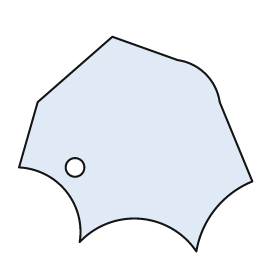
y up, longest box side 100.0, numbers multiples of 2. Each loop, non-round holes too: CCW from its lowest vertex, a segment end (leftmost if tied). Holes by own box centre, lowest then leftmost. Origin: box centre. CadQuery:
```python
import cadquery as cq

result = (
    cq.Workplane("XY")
    .moveTo(26.0, -46.0)
    .threePointArc((34.0, -28.0), (50.0, -16.0))
    .lineTo(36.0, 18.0)
    .threePointArc((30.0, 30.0), (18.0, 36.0))
    .lineTo(-10.0, 46.0)
    .lineTo(-42.0, 18.0)
    .lineTo(-50.0, -10.0)
    .threePointArc((-30.0, -20.0), (-24.0, -42.0))
    .threePointArc((2.0, -32.0), (26.0, -46.0))
    .close()
    .moveTo(-26.0, -10.0)
    .circle(4.0)
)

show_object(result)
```